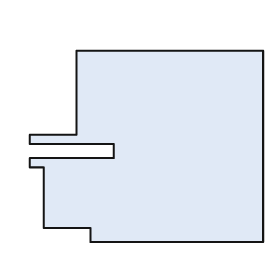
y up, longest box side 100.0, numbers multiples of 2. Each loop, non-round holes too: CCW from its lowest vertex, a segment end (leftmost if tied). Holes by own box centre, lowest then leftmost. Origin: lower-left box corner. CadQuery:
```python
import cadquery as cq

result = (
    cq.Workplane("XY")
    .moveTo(26.0, 0.0)
    .lineTo(100.0, 0.0)
    .lineTo(100.0, 82.0)
    .lineTo(20.0, 82.0)
    .lineTo(20.0, 46.0)
    .lineTo(0.0, 46.0)
    .lineTo(0.0, 42.0)
    .lineTo(36.0, 42.0)
    .lineTo(36.0, 36.0)
    .lineTo(0.0, 36.0)
    .lineTo(0.0, 32.0)
    .lineTo(6.0, 32.0)
    .lineTo(6.0, 6.0)
    .lineTo(26.0, 6.0)
    .close()
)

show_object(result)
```